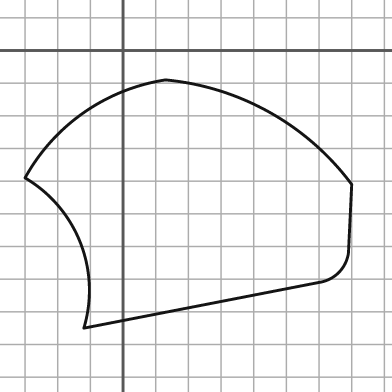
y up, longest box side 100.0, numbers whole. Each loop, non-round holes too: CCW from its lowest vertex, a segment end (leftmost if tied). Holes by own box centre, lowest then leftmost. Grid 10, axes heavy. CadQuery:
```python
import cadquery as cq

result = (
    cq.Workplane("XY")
    .moveTo(-12.0, -85.0)
    .lineTo(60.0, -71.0)
    .threePointArc((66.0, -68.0), (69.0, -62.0))
    .lineTo(70.0, -41.0)
    .threePointArc((45.0, -19.0), (13.0, -9.0))
    .threePointArc((-12.0, -19.0), (-30.0, -39.0))
    .threePointArc((-13.0, -59.0), (-12.0, -85.0))
    .close()
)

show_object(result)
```